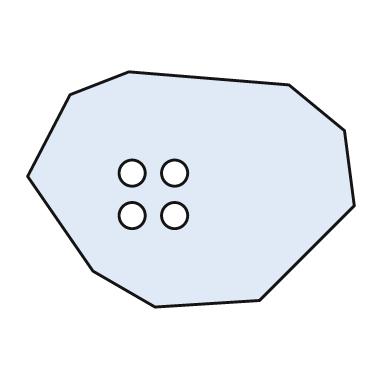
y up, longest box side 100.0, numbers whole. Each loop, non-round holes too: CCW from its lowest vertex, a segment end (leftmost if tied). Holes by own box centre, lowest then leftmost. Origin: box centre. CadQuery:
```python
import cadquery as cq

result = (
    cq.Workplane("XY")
    .moveTo(-11.0, -36.0)
    .lineTo(21.0, -34.0)
    .lineTo(50.0, -5.0)
    .lineTo(47.0, 18.0)
    .lineTo(30.0, 32.0)
    .lineTo(-19.0, 36.0)
    .lineTo(-37.0, 29.0)
    .lineTo(-50.0, 4.0)
    .lineTo(-30.0, -25.0)
    .close()
    .moveTo(-18.0, -8.0)
    .circle(4.0)
    .moveTo(-5.0, -8.0)
    .circle(4.0)
    .moveTo(-18.0, 5.0)
    .circle(4.0)
    .moveTo(-5.0, 5.0)
    .circle(4.0)
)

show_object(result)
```